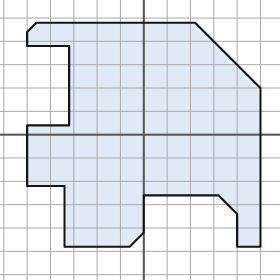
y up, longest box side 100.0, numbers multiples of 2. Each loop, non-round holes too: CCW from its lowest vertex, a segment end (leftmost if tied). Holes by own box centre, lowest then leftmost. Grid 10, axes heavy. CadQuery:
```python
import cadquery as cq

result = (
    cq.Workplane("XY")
    .moveTo(-34.0, -48.0)
    .lineTo(-6.0, -48.0)
    .lineTo(0.0, -42.0)
    .lineTo(0.0, -26.0)
    .lineTo(32.0, -26.0)
    .lineTo(40.0, -34.0)
    .lineTo(40.0, -48.0)
    .lineTo(50.0, -48.0)
    .lineTo(50.0, 20.0)
    .lineTo(22.0, 48.0)
    .lineTo(-46.0, 48.0)
    .lineTo(-50.0, 44.0)
    .lineTo(-50.0, 38.0)
    .lineTo(-32.0, 38.0)
    .lineTo(-32.0, 4.0)
    .lineTo(-50.0, 4.0)
    .lineTo(-50.0, -22.0)
    .lineTo(-34.0, -22.0)
    .close()
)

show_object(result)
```